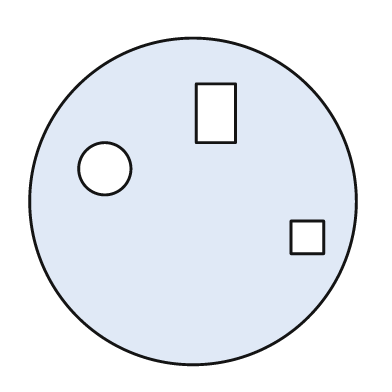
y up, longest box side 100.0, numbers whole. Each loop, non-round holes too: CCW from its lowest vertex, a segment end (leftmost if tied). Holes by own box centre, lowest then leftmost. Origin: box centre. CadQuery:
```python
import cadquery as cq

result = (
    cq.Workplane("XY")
    .moveTo(0.0, 0.0)
    .circle(50.0)
    .moveTo(30.0, -16.0)
    .lineTo(40.0, -16.0)
    .lineTo(40.0, -6.0)
    .lineTo(30.0, -6.0)
    .close()
    .moveTo(-27.0, 10.0)
    .circle(8.0)
    .moveTo(1.0, 18.0)
    .lineTo(13.0, 18.0)
    .lineTo(13.0, 36.0)
    .lineTo(1.0, 36.0)
    .close()
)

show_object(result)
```